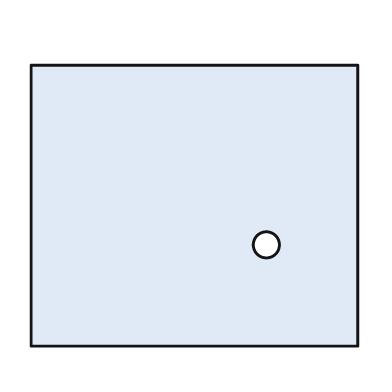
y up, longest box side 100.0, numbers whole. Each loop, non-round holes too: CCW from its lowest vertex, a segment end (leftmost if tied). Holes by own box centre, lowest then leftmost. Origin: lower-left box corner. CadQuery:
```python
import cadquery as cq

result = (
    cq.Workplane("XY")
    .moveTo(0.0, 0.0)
    .lineTo(100.0, 0.0)
    .lineTo(100.0, 86.0)
    .lineTo(0.0, 86.0)
    .close()
    .moveTo(72.0, 31.0)
    .circle(4.0)
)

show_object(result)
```